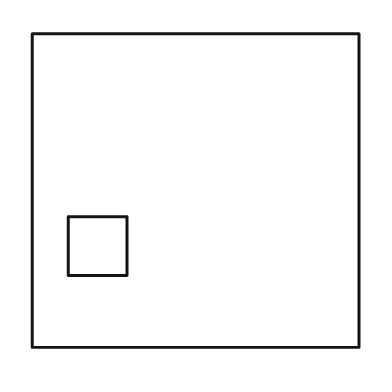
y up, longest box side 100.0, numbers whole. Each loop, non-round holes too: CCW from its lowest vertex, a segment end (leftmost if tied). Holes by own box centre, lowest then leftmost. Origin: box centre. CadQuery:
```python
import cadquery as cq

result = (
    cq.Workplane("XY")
    .moveTo(-50.0, -48.0)
    .lineTo(50.0, -48.0)
    .lineTo(50.0, 48.0)
    .lineTo(-50.0, 48.0)
    .close()
    .moveTo(-39.0, -26.0)
    .lineTo(-21.0, -26.0)
    .lineTo(-21.0, -8.0)
    .lineTo(-39.0, -8.0)
    .close()
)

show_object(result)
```